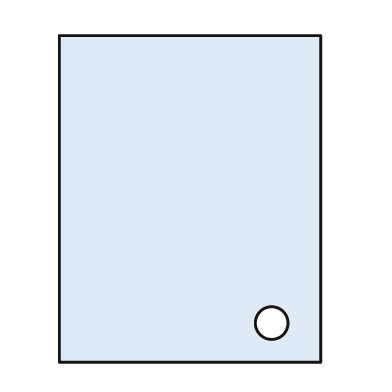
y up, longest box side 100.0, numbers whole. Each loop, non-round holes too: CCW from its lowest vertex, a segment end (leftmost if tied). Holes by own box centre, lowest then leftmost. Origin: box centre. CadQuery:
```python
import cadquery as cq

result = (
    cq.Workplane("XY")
    .moveTo(-40.0, -50.0)
    .lineTo(40.0, -50.0)
    .lineTo(40.0, 50.0)
    .lineTo(-40.0, 50.0)
    .close()
    .moveTo(25.0, -38.0)
    .circle(5.0)
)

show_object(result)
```